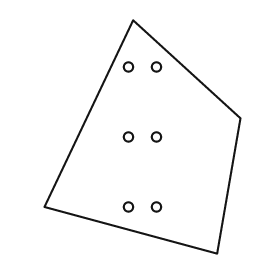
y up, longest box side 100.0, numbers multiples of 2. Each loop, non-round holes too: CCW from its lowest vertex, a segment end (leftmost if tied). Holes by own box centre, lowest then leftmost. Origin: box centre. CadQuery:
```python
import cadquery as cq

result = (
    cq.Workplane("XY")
    .moveTo(32.0, -50.0)
    .lineTo(42.0, 8.0)
    .lineTo(-4.0, 50.0)
    .lineTo(-42.0, -30.0)
    .close()
    .moveTo(-6.0, -30.0)
    .circle(2.0)
    .moveTo(6.0, -30.0)
    .circle(2.0)
    .moveTo(-6.0, 0.0)
    .circle(2.0)
    .moveTo(6.0, 0.0)
    .circle(2.0)
    .moveTo(-6.0, 30.0)
    .circle(2.0)
    .moveTo(6.0, 30.0)
    .circle(2.0)
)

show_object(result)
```